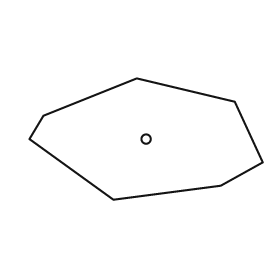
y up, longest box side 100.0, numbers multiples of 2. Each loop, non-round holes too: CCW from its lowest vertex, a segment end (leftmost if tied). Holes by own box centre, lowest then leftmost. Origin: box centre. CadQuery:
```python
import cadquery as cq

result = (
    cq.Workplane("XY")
    .moveTo(-14.0, -26.0)
    .lineTo(32.0, -20.0)
    .lineTo(50.0, -10.0)
    .lineTo(38.0, 16.0)
    .lineTo(-4.0, 26.0)
    .lineTo(-44.0, 10.0)
    .lineTo(-50.0, 0.0)
    .close()
    .moveTo(0.0, 0.0)
    .circle(2.0)
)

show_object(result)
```